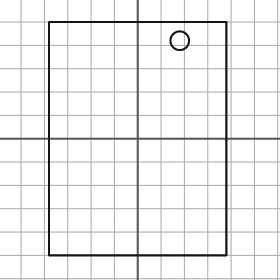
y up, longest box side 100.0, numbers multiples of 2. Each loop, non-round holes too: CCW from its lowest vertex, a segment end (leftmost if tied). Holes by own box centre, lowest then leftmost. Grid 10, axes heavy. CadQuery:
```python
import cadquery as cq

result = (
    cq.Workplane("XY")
    .moveTo(-38.0, -50.0)
    .lineTo(38.0, -50.0)
    .lineTo(38.0, 50.0)
    .lineTo(-38.0, 50.0)
    .close()
    .moveTo(18.0, 42.0)
    .circle(4.0)
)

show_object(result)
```